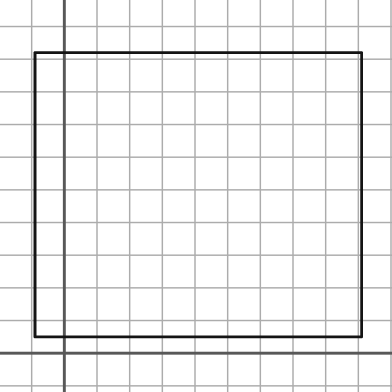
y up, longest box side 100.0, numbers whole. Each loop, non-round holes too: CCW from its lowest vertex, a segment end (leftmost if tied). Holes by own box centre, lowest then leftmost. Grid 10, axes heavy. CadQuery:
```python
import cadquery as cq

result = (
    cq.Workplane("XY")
    .moveTo(-9.0, 5.0)
    .lineTo(91.0, 5.0)
    .lineTo(91.0, 92.0)
    .lineTo(-9.0, 92.0)
    .close()
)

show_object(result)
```